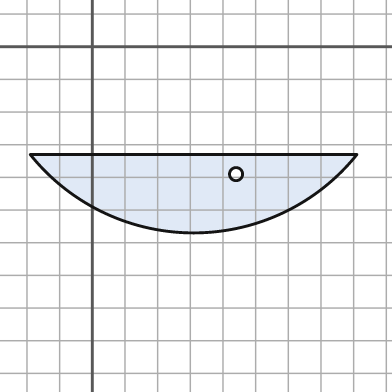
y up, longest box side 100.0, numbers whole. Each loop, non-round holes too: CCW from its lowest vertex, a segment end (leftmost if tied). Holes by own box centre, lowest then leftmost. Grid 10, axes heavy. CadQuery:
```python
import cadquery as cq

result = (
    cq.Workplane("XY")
    .moveTo(-19.0, -33.0)
    .threePointArc((31.0, -57.0), (81.0, -33.0))
    .close()
    .moveTo(44.0, -39.0)
    .circle(2.0)
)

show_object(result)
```